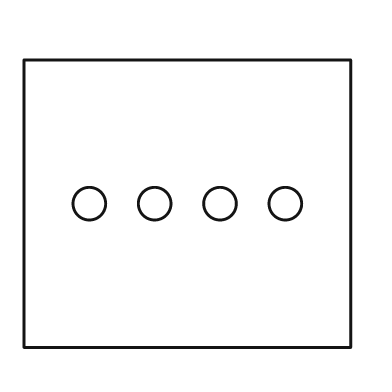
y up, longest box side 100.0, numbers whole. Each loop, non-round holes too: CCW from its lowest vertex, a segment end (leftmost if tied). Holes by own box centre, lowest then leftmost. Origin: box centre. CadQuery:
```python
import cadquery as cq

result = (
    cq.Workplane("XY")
    .moveTo(-50.0, -44.0)
    .lineTo(50.0, -44.0)
    .lineTo(50.0, 44.0)
    .lineTo(-50.0, 44.0)
    .close()
    .moveTo(-30.0, 0.0)
    .circle(5.0)
    .moveTo(-10.0, 0.0)
    .circle(5.0)
    .moveTo(10.0, 0.0)
    .circle(5.0)
    .moveTo(30.0, 0.0)
    .circle(5.0)
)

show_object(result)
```